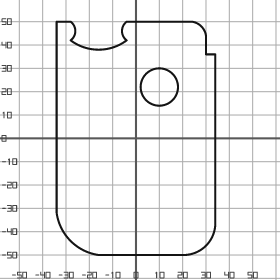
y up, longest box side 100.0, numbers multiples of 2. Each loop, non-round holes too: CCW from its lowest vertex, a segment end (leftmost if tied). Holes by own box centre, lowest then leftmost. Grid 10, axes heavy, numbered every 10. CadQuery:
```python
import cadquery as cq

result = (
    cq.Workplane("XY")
    .moveTo(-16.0, -50.0)
    .lineTo(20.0, -50.0)
    .threePointArc((30.0, -46.0), (34.0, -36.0))
    .lineTo(34.0, 36.0)
    .lineTo(30.0, 36.0)
    .lineTo(30.0, 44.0)
    .threePointArc((28.0, 48.0), (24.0, 50.0))
    .lineTo(-4.0, 50.0)
    .threePointArc((-6.0, 46.0), (-4.0, 42.0))
    .threePointArc((-16.0, 38.0), (-28.0, 42.0))
    .threePointArc((-26.0, 46.0), (-28.0, 50.0))
    .lineTo(-34.0, 50.0)
    .lineTo(-34.0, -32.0)
    .threePointArc((-28.0, -44.0), (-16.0, -50.0))
    .close()
    .moveTo(10.0, 22.0)
    .circle(8.0)
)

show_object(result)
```